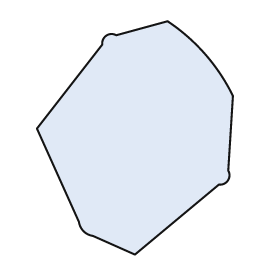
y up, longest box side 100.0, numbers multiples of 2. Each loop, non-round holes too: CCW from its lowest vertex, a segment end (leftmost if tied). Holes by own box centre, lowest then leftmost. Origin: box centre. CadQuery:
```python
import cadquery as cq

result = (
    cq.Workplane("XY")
    .moveTo(0.0, -50.0)
    .lineTo(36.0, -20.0)
    .threePointArc((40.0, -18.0), (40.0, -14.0))
    .lineTo(42.0, 18.0)
    .threePointArc((30.0, 36.0), (14.0, 50.0))
    .lineTo(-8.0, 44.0)
    .threePointArc((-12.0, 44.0), (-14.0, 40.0))
    .lineTo(-42.0, 4.0)
    .lineTo(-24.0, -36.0)
    .threePointArc((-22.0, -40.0), (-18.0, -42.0))
    .close()
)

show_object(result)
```